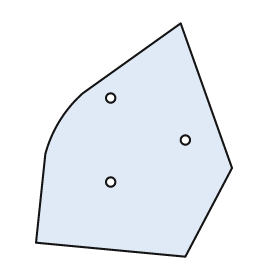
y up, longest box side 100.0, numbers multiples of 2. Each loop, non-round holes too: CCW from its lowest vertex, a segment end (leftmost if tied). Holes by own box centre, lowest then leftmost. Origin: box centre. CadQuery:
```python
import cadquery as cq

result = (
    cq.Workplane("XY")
    .moveTo(22.0, -50.0)
    .lineTo(42.0, -12.0)
    .lineTo(20.0, 50.0)
    .lineTo(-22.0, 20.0)
    .threePointArc((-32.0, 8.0), (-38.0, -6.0))
    .lineTo(-42.0, -44.0)
    .close()
    .moveTo(-10.0, -18.0)
    .circle(2.0)
    .moveTo(22.0, 0.0)
    .circle(2.0)
    .moveTo(-10.0, 18.0)
    .circle(2.0)
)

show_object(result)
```